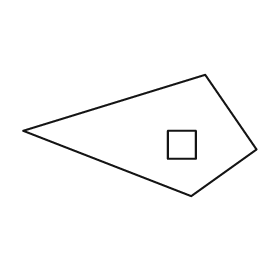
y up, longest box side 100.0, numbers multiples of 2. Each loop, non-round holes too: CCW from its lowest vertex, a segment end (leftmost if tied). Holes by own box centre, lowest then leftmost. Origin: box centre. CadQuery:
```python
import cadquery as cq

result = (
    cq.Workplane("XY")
    .moveTo(22.0, -26.0)
    .lineTo(50.0, -6.0)
    .lineTo(28.0, 26.0)
    .lineTo(-50.0, 2.0)
    .close()
    .moveTo(12.0, -10.0)
    .lineTo(24.0, -10.0)
    .lineTo(24.0, 2.0)
    .lineTo(12.0, 2.0)
    .close()
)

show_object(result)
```